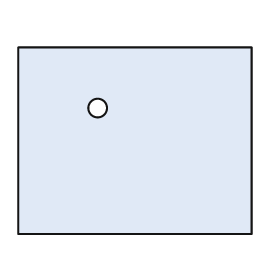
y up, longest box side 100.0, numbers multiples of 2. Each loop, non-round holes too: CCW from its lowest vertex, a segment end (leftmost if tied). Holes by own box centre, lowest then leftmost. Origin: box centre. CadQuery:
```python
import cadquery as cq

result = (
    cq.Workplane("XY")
    .moveTo(-50.0, -40.0)
    .lineTo(50.0, -40.0)
    .lineTo(50.0, 40.0)
    .lineTo(-50.0, 40.0)
    .close()
    .moveTo(-16.0, 14.0)
    .circle(4.0)
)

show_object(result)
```